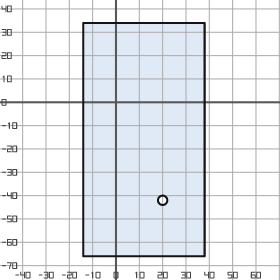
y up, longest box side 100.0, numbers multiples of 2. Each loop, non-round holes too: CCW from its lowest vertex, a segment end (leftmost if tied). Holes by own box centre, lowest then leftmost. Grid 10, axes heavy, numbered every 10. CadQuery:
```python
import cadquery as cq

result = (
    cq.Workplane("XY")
    .moveTo(-14.0, -66.0)
    .lineTo(38.0, -66.0)
    .lineTo(38.0, 34.0)
    .lineTo(-14.0, 34.0)
    .close()
    .moveTo(20.0, -42.0)
    .circle(2.0)
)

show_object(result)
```